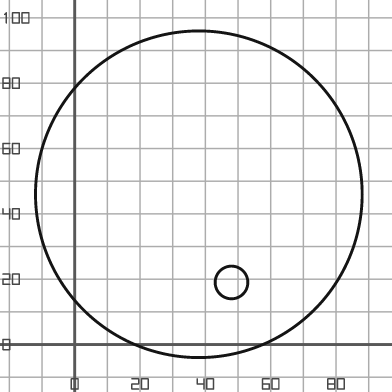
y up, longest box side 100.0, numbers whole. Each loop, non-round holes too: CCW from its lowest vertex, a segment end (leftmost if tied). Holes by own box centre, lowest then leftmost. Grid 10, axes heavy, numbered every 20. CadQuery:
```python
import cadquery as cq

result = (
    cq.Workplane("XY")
    .moveTo(38.0, 46.0)
    .circle(50.0)
    .moveTo(48.0, 19.0)
    .circle(5.0)
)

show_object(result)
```